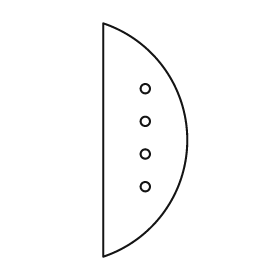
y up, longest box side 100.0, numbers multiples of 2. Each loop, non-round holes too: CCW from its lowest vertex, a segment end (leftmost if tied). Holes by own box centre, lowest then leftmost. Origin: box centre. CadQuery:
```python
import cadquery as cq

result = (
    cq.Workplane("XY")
    .moveTo(-18.0, -50.0)
    .threePointArc((18.0, 0.0), (-18.0, 50.0))
    .close()
    .moveTo(0.0, -20.0)
    .circle(2.0)
    .moveTo(0.0, -6.0)
    .circle(2.0)
    .moveTo(0.0, 8.0)
    .circle(2.0)
    .moveTo(0.0, 22.0)
    .circle(2.0)
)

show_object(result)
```